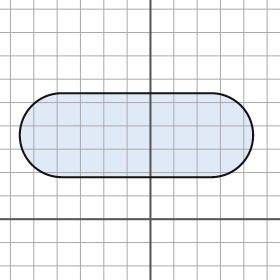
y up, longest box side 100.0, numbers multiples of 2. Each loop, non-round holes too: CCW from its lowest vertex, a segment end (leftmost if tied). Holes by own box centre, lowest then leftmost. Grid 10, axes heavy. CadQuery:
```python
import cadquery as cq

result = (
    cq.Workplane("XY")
    .moveTo(-38.0, 18.0)
    .lineTo(26.0, 18.0)
    .threePointArc((44.0, 36.0), (26.0, 54.0))
    .lineTo(-38.0, 54.0)
    .threePointArc((-56.0, 36.0), (-38.0, 18.0))
    .close()
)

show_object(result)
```